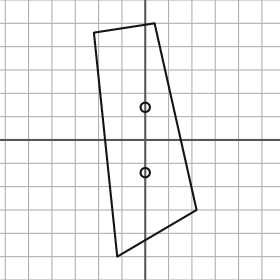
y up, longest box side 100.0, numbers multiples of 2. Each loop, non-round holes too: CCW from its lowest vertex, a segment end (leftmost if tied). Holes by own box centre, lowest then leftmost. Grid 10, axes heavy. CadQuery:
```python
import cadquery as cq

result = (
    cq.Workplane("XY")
    .moveTo(-12.0, -50.0)
    .lineTo(22.0, -30.0)
    .lineTo(4.0, 50.0)
    .lineTo(-22.0, 46.0)
    .close()
    .moveTo(0.0, -14.0)
    .circle(2.0)
    .moveTo(0.0, 14.0)
    .circle(2.0)
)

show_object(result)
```